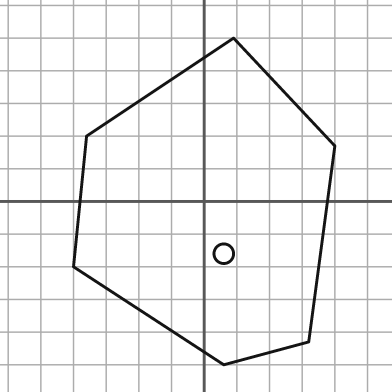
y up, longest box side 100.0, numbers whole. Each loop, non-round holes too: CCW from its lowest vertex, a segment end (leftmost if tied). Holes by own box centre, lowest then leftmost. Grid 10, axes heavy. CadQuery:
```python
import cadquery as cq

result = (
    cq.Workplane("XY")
    .moveTo(6.0, -50.0)
    .lineTo(32.0, -43.0)
    .lineTo(40.0, 17.0)
    .lineTo(9.0, 50.0)
    .lineTo(-36.0, 20.0)
    .lineTo(-40.0, -20.0)
    .close()
    .moveTo(6.0, -16.0)
    .circle(3.0)
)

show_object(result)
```